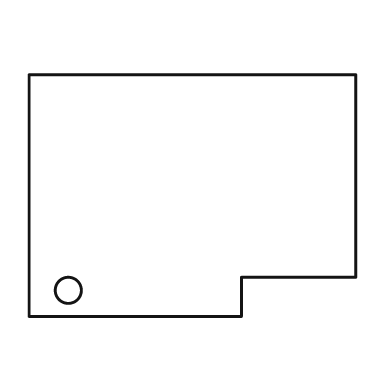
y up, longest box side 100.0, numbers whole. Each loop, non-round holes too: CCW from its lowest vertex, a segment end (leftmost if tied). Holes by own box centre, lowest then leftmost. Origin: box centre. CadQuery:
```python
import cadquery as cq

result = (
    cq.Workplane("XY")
    .moveTo(-50.0, -37.0)
    .lineTo(15.0, -37.0)
    .lineTo(15.0, -25.0)
    .lineTo(50.0, -25.0)
    .lineTo(50.0, 37.0)
    .lineTo(-50.0, 37.0)
    .close()
    .moveTo(-38.0, -29.0)
    .circle(4.0)
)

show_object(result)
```